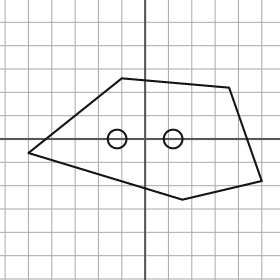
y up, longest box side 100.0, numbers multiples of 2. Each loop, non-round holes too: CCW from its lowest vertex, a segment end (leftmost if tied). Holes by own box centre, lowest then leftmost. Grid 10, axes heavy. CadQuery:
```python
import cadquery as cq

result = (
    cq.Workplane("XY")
    .moveTo(16.0, -26.0)
    .lineTo(50.0, -18.0)
    .lineTo(36.0, 22.0)
    .lineTo(-10.0, 26.0)
    .lineTo(-50.0, -6.0)
    .close()
    .moveTo(-12.0, 0.0)
    .circle(4.0)
    .moveTo(12.0, 0.0)
    .circle(4.0)
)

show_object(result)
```